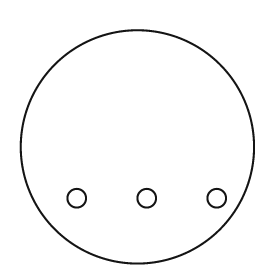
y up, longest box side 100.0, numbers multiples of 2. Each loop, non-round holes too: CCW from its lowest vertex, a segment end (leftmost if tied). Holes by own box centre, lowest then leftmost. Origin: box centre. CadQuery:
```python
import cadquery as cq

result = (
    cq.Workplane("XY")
    .moveTo(0.0, 0.0)
    .circle(50.0)
    .moveTo(-26.0, -22.0)
    .circle(4.0)
    .moveTo(4.0, -22.0)
    .circle(4.0)
    .moveTo(34.0, -22.0)
    .circle(4.0)
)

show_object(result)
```